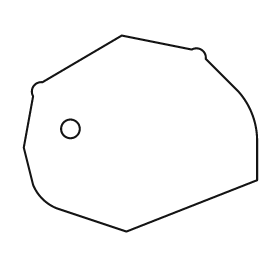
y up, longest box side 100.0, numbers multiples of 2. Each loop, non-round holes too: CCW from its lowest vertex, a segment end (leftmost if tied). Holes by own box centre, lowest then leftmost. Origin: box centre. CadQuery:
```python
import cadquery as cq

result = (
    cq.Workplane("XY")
    .moveTo(-6.0, -42.0)
    .lineTo(50.0, -20.0)
    .lineTo(50.0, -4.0)
    .threePointArc((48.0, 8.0), (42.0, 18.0))
    .lineTo(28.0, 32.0)
    .threePointArc((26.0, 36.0), (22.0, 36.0))
    .lineTo(-8.0, 42.0)
    .lineTo(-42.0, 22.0)
    .threePointArc((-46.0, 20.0), (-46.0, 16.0))
    .lineTo(-50.0, -6.0)
    .lineTo(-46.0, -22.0)
    .threePointArc((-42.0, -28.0), (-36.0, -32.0))
    .close()
    .moveTo(-30.0, 2.0)
    .circle(4.0)
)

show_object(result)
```